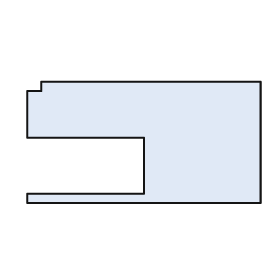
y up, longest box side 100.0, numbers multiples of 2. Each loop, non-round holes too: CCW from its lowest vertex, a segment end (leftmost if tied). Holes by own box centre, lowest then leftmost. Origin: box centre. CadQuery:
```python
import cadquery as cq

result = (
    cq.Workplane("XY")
    .moveTo(-50.0, -26.0)
    .lineTo(50.0, -26.0)
    .lineTo(50.0, 26.0)
    .lineTo(-44.0, 26.0)
    .lineTo(-44.0, 22.0)
    .lineTo(-50.0, 22.0)
    .lineTo(-50.0, 2.0)
    .lineTo(0.0, 2.0)
    .lineTo(0.0, -22.0)
    .lineTo(-50.0, -22.0)
    .close()
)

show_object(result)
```